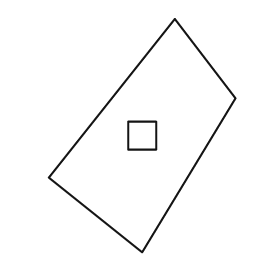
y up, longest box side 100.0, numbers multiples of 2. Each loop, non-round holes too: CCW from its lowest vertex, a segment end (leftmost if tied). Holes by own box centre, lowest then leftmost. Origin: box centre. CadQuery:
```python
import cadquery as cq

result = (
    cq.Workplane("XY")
    .moveTo(0.0, -50.0)
    .lineTo(40.0, 16.0)
    .lineTo(14.0, 50.0)
    .lineTo(-40.0, -18.0)
    .close()
    .moveTo(-6.0, -6.0)
    .lineTo(6.0, -6.0)
    .lineTo(6.0, 6.0)
    .lineTo(-6.0, 6.0)
    .close()
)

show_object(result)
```